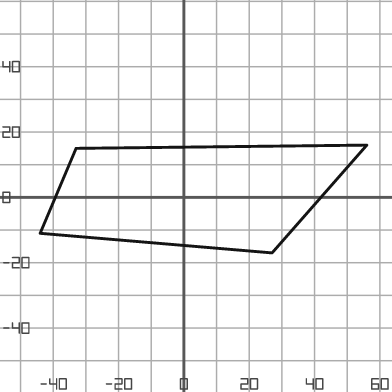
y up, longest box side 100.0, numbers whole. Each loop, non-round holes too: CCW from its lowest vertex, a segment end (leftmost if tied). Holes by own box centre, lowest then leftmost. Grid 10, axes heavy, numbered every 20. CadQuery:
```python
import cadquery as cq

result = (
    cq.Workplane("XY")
    .moveTo(27.0, -17.0)
    .lineTo(56.0, 16.0)
    .lineTo(-33.0, 15.0)
    .lineTo(-44.0, -11.0)
    .close()
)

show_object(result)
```